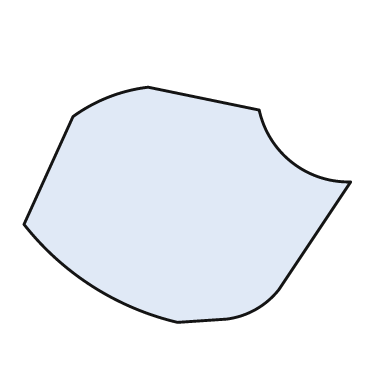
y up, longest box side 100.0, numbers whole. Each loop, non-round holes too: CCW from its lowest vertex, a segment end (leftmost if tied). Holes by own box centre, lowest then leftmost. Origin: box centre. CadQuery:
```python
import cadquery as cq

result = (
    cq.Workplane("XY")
    .moveTo(-3.0, -36.0)
    .lineTo(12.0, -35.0)
    .threePointArc((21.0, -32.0), (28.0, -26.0))
    .lineTo(50.0, 7.0)
    .threePointArc((32.0, 13.0), (22.0, 29.0))
    .lineTo(-12.0, 36.0)
    .threePointArc((-24.0, 33.0), (-35.0, 27.0))
    .lineTo(-50.0, -6.0)
    .threePointArc((-29.0, -25.0), (-3.0, -36.0))
    .close()
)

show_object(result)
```